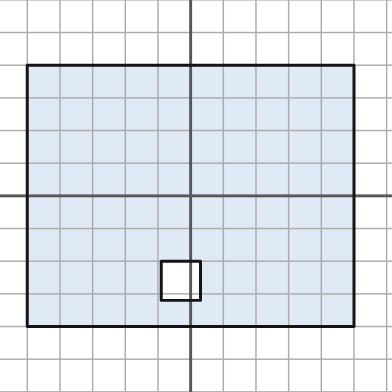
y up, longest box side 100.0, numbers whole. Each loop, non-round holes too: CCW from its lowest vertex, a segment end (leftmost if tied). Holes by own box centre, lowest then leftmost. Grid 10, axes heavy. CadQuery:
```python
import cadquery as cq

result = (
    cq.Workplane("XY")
    .moveTo(-50.0, -40.0)
    .lineTo(50.0, -40.0)
    .lineTo(50.0, 40.0)
    .lineTo(-50.0, 40.0)
    .close()
    .moveTo(-9.0, -32.0)
    .lineTo(3.0, -32.0)
    .lineTo(3.0, -20.0)
    .lineTo(-9.0, -20.0)
    .close()
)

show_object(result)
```